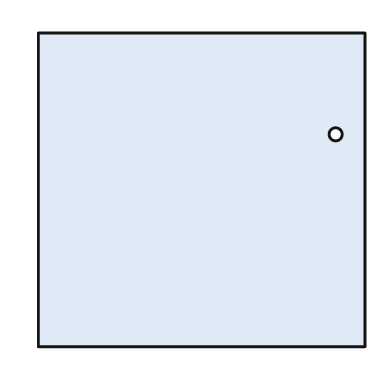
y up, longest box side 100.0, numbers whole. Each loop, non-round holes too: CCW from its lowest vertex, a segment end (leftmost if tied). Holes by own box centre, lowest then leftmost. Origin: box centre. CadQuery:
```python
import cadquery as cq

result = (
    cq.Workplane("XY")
    .moveTo(-50.0, -48.0)
    .lineTo(50.0, -48.0)
    .lineTo(50.0, 48.0)
    .lineTo(-50.0, 48.0)
    .close()
    .moveTo(41.0, 17.0)
    .circle(2.0)
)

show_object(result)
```